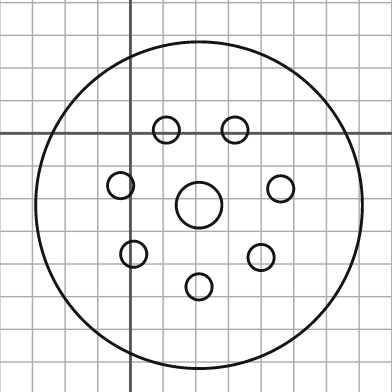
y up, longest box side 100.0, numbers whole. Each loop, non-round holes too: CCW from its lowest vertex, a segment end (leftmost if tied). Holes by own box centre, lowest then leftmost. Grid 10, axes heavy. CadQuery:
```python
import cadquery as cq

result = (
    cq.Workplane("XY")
    .moveTo(21.0, -22.0)
    .circle(50.0)
    .moveTo(21.0, -47.0)
    .circle(4.0)
    .moveTo(40.0, -38.0)
    .circle(4.0)
    .moveTo(1.0, -37.0)
    .circle(4.0)
    .moveTo(21.0, -22.0)
    .circle(7.0)
    .moveTo(46.0, -17.0)
    .circle(4.0)
    .moveTo(-3.0, -16.0)
    .circle(4.0)
    .moveTo(11.0, 1.0)
    .circle(4.0)
    .moveTo(32.0, 1.0)
    .circle(4.0)
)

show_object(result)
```